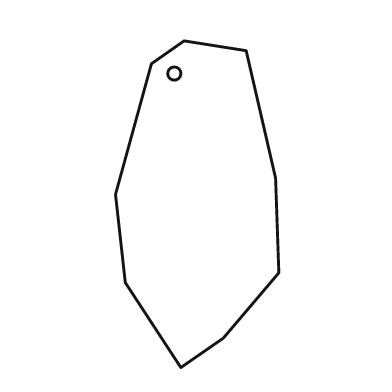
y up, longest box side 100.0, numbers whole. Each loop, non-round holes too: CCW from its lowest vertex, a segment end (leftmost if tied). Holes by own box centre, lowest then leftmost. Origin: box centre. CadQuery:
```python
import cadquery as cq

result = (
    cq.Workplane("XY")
    .moveTo(-5.0, -50.0)
    .lineTo(8.0, -41.0)
    .lineTo(25.0, -21.0)
    .lineTo(24.0, 8.0)
    .lineTo(15.0, 47.0)
    .lineTo(-4.0, 50.0)
    .lineTo(-14.0, 43.0)
    .lineTo(-25.0, 3.0)
    .lineTo(-22.0, -24.0)
    .close()
    .moveTo(-7.0, 40.0)
    .circle(2.0)
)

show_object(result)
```